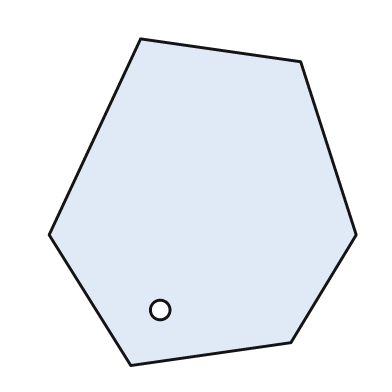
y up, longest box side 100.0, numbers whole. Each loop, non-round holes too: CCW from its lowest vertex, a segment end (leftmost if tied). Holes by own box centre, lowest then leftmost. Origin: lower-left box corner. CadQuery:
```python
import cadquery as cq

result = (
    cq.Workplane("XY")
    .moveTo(25.0, 0.0)
    .lineTo(74.0, 7.0)
    .lineTo(94.0, 40.0)
    .lineTo(77.0, 93.0)
    .lineTo(28.0, 100.0)
    .lineTo(0.0, 40.0)
    .close()
    .moveTo(34.0, 17.0)
    .circle(3.0)
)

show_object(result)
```